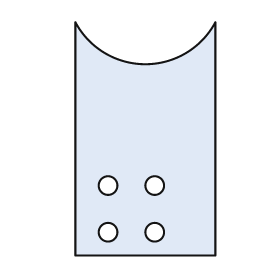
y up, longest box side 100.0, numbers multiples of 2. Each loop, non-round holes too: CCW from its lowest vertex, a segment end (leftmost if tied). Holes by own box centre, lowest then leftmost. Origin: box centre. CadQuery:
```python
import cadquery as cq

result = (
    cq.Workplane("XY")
    .moveTo(-30.0, -50.0)
    .lineTo(30.0, -50.0)
    .lineTo(30.0, 50.0)
    .threePointArc((0.0, 32.0), (-30.0, 50.0))
    .close()
    .moveTo(-16.0, -40.0)
    .circle(4.0)
    .moveTo(4.0, -40.0)
    .circle(4.0)
    .moveTo(-16.0, -20.0)
    .circle(4.0)
    .moveTo(4.0, -20.0)
    .circle(4.0)
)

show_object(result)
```